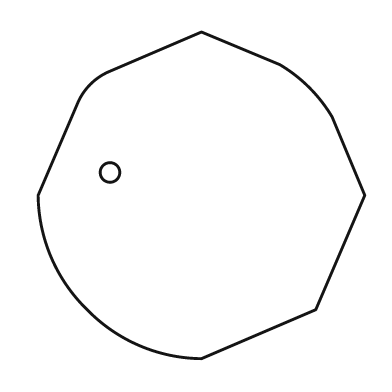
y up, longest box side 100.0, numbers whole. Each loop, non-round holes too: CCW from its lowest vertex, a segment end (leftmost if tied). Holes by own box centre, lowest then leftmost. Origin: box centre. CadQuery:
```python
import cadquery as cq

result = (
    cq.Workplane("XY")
    .moveTo(0.0, -50.0)
    .lineTo(35.0, -35.0)
    .lineTo(50.0, 0.0)
    .lineTo(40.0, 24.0)
    .threePointArc((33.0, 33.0), (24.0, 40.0))
    .lineTo(0.0, 50.0)
    .lineTo(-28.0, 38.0)
    .threePointArc((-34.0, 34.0), (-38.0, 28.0))
    .lineTo(-50.0, 0.0)
    .threePointArc((-46.0, -19.0), (-35.0, -35.0))
    .threePointArc((-19.0, -46.0), (0.0, -50.0))
    .close()
    .moveTo(-28.0, 7.0)
    .circle(3.0)
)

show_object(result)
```